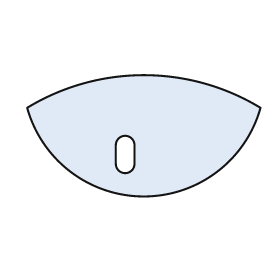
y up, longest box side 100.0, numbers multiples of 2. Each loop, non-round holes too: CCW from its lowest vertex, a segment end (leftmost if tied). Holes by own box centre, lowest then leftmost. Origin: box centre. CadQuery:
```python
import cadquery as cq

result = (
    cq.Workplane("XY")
    .moveTo(-50.0, 12.0)
    .threePointArc((0.0, -26.0), (50.0, 12.0))
    .threePointArc((0.0, 26.0), (-50.0, 12.0))
    .close()
    .moveTo(-12.0, -12.0)
    .threePointArc((-8.0, -16.0), (-4.0, -12.0))
    .lineTo(-4.0, -4.0)
    .threePointArc((-8.0, 0.0), (-12.0, -4.0))
    .close()
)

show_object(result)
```